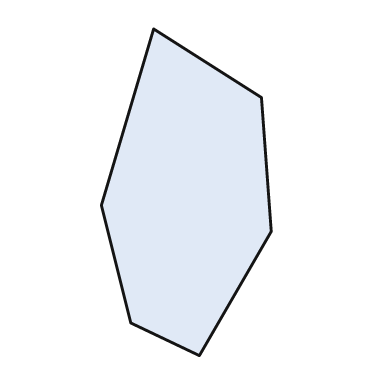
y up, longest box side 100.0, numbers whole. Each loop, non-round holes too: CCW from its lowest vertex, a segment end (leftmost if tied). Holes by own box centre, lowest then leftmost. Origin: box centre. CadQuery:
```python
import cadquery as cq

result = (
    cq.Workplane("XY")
    .moveTo(4.0, -50.0)
    .lineTo(26.0, -12.0)
    .lineTo(23.0, 29.0)
    .lineTo(-10.0, 50.0)
    .lineTo(-26.0, -4.0)
    .lineTo(-17.0, -40.0)
    .close()
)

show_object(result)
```